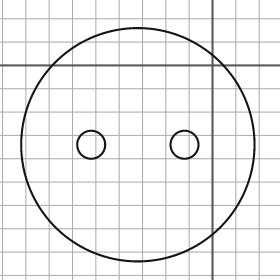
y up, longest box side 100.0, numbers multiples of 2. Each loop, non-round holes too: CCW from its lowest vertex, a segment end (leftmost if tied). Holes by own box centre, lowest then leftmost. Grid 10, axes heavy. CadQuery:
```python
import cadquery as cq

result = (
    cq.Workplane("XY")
    .moveTo(-32.0, -34.0)
    .circle(50.0)
    .moveTo(-52.0, -34.0)
    .circle(6.0)
    .moveTo(-12.0, -34.0)
    .circle(6.0)
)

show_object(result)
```